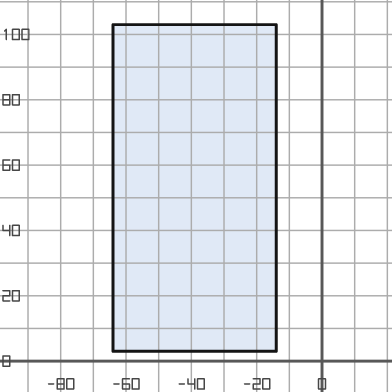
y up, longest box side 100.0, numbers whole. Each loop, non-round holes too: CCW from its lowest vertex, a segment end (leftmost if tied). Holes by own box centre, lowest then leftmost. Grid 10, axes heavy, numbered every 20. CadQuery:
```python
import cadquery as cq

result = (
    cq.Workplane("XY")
    .moveTo(-64.0, 3.0)
    .lineTo(-14.0, 3.0)
    .lineTo(-14.0, 103.0)
    .lineTo(-64.0, 103.0)
    .close()
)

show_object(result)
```